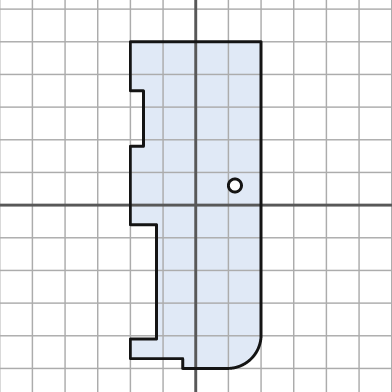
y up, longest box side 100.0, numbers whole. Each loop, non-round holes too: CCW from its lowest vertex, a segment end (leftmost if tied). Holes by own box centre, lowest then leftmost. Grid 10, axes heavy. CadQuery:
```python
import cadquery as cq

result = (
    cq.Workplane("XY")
    .moveTo(-4.0, -50.0)
    .lineTo(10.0, -50.0)
    .threePointArc((17.0, -47.0), (20.0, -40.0))
    .lineTo(20.0, 50.0)
    .lineTo(-20.0, 50.0)
    .lineTo(-20.0, 35.0)
    .lineTo(-16.0, 35.0)
    .lineTo(-16.0, 18.0)
    .lineTo(-20.0, 18.0)
    .lineTo(-20.0, -6.0)
    .lineTo(-12.0, -6.0)
    .lineTo(-12.0, -41.0)
    .lineTo(-20.0, -41.0)
    .lineTo(-20.0, -47.0)
    .lineTo(-4.0, -47.0)
    .close()
    .moveTo(12.0, 6.0)
    .circle(2.0)
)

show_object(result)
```